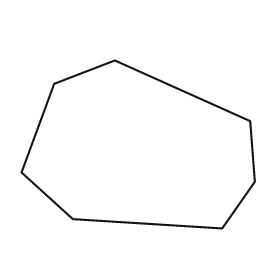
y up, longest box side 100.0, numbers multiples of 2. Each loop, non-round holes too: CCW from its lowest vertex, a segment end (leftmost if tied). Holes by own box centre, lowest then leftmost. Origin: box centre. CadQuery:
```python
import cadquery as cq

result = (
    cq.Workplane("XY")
    .moveTo(36.0, -36.0)
    .lineTo(50.0, -16.0)
    .lineTo(48.0, 10.0)
    .lineTo(-10.0, 36.0)
    .lineTo(-36.0, 26.0)
    .lineTo(-50.0, -12.0)
    .lineTo(-28.0, -32.0)
    .close()
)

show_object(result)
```